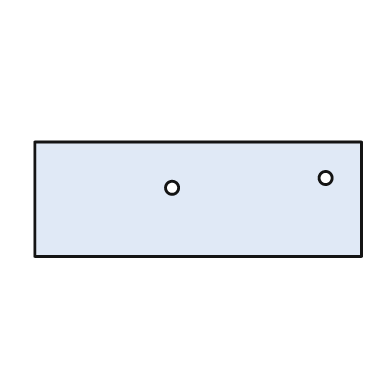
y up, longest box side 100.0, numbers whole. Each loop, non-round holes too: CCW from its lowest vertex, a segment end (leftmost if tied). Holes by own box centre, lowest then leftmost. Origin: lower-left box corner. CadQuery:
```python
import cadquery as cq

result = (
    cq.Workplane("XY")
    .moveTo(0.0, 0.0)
    .lineTo(100.0, 0.0)
    .lineTo(100.0, 35.0)
    .lineTo(0.0, 35.0)
    .close()
    .moveTo(42.0, 21.0)
    .circle(2.0)
    .moveTo(89.0, 24.0)
    .circle(2.0)
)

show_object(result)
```